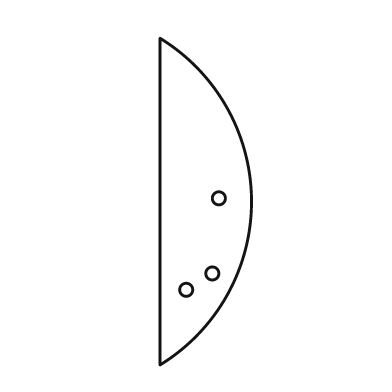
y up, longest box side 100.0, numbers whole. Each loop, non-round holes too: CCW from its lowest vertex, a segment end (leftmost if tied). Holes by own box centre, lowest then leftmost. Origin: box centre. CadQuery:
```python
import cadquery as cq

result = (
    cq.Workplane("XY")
    .moveTo(-14.0, -50.0)
    .threePointArc((14.0, 0.0), (-14.0, 50.0))
    .close()
    .moveTo(-6.0, -27.0)
    .circle(2.0)
    .moveTo(2.0, -22.0)
    .circle(2.0)
    .moveTo(4.0, 1.0)
    .circle(2.0)
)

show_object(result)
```